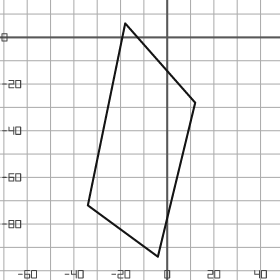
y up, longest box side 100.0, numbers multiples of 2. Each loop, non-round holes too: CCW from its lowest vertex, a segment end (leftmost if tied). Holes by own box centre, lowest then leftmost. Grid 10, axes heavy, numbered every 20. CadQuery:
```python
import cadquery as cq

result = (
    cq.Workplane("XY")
    .moveTo(-4.0, -94.0)
    .lineTo(12.0, -28.0)
    .lineTo(-18.0, 6.0)
    .lineTo(-34.0, -72.0)
    .close()
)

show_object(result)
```